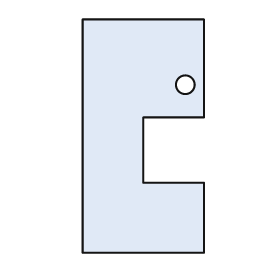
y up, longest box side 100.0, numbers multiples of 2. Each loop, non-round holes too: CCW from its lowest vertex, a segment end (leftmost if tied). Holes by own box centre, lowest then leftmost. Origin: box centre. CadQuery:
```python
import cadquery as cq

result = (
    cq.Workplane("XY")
    .moveTo(-26.0, -50.0)
    .lineTo(26.0, -50.0)
    .lineTo(26.0, -20.0)
    .lineTo(0.0, -20.0)
    .lineTo(0.0, 8.0)
    .lineTo(26.0, 8.0)
    .lineTo(26.0, 50.0)
    .lineTo(-26.0, 50.0)
    .close()
    .moveTo(18.0, 22.0)
    .circle(4.0)
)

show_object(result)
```